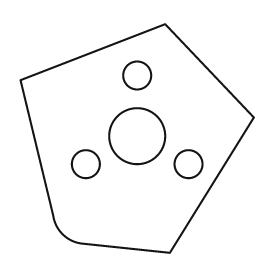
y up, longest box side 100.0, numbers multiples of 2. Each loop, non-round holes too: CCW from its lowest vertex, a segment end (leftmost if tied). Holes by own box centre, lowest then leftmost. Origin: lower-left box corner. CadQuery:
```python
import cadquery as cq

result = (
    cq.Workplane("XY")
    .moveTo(64.0, 0.0)
    .lineTo(100.0, 58.0)
    .lineTo(62.0, 98.0)
    .lineTo(0.0, 74.0)
    .lineTo(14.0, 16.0)
    .threePointArc((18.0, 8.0), (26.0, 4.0))
    .close()
    .moveTo(28.0, 38.0)
    .circle(6.0)
    .moveTo(72.0, 38.0)
    .circle(6.0)
    .moveTo(50.0, 50.0)
    .circle(12.0)
    .moveTo(50.0, 76.0)
    .circle(6.0)
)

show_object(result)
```